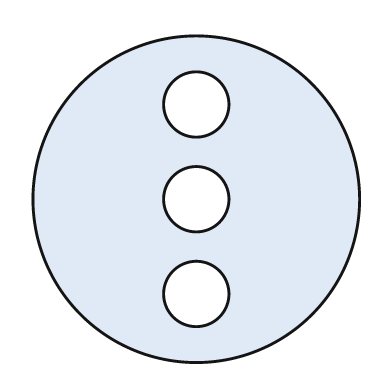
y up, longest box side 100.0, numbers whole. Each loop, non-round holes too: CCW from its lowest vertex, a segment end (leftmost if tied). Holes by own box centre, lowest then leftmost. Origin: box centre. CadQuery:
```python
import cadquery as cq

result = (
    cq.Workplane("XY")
    .moveTo(0.0, 0.0)
    .circle(50.0)
    .moveTo(0.0, -29.0)
    .circle(10.0)
    .moveTo(0.0, 0.0)
    .circle(10.0)
    .moveTo(0.0, 29.0)
    .circle(10.0)
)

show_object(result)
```